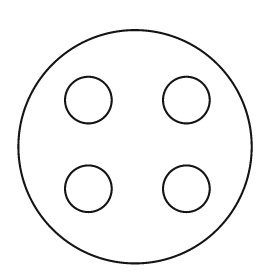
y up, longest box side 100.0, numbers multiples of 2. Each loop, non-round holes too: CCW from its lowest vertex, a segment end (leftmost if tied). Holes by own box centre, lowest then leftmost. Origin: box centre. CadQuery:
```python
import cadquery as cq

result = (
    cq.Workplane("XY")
    .moveTo(0.0, 0.0)
    .circle(50.0)
    .moveTo(-20.0, -18.0)
    .circle(10.0)
    .moveTo(22.0, -18.0)
    .circle(10.0)
    .moveTo(-20.0, 20.0)
    .circle(10.0)
    .moveTo(22.0, 20.0)
    .circle(10.0)
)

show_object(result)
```